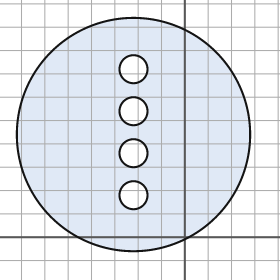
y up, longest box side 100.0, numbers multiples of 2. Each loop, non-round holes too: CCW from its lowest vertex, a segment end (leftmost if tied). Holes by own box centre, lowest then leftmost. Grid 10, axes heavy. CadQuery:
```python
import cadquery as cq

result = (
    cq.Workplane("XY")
    .moveTo(-22.0, 44.0)
    .circle(50.0)
    .moveTo(-22.0, 18.0)
    .circle(6.0)
    .moveTo(-22.0, 36.0)
    .circle(6.0)
    .moveTo(-22.0, 54.0)
    .circle(6.0)
    .moveTo(-22.0, 72.0)
    .circle(6.0)
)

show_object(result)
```